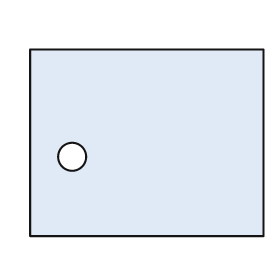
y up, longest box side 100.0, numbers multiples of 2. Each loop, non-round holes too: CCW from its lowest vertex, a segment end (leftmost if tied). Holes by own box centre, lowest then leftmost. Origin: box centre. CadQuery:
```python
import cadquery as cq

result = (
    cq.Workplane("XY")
    .moveTo(-50.0, -40.0)
    .lineTo(50.0, -40.0)
    .lineTo(50.0, 40.0)
    .lineTo(-50.0, 40.0)
    .close()
    .moveTo(-32.0, -6.0)
    .circle(6.0)
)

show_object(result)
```